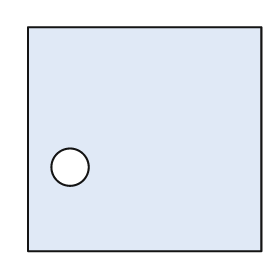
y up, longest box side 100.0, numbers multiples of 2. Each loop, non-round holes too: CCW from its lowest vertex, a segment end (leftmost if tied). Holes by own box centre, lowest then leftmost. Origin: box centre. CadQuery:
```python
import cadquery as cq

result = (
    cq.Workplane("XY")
    .moveTo(-50.0, -48.0)
    .lineTo(50.0, -48.0)
    .lineTo(50.0, 48.0)
    .lineTo(-50.0, 48.0)
    .close()
    .moveTo(-32.0, -12.0)
    .circle(8.0)
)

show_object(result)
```